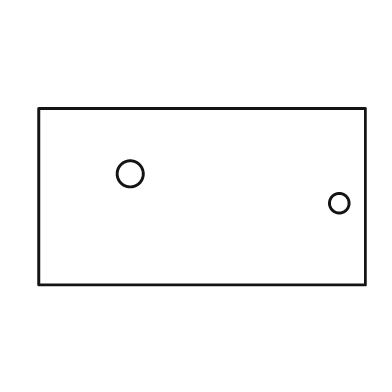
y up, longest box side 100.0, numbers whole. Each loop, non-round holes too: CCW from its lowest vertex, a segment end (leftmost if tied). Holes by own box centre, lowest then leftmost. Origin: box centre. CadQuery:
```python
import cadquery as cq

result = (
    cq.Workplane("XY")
    .moveTo(-50.0, -27.0)
    .lineTo(50.0, -27.0)
    .lineTo(50.0, 27.0)
    .lineTo(-50.0, 27.0)
    .close()
    .moveTo(42.0, -2.0)
    .circle(3.0)
    .moveTo(-22.0, 7.0)
    .circle(4.0)
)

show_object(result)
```